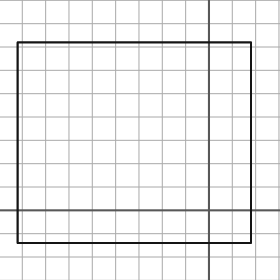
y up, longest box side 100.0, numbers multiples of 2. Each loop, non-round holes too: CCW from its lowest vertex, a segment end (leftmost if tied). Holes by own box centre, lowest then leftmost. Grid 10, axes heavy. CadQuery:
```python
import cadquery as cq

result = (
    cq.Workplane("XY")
    .moveTo(-82.0, -14.0)
    .lineTo(18.0, -14.0)
    .lineTo(18.0, 72.0)
    .lineTo(-82.0, 72.0)
    .close()
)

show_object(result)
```